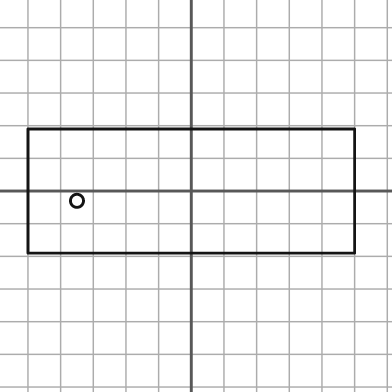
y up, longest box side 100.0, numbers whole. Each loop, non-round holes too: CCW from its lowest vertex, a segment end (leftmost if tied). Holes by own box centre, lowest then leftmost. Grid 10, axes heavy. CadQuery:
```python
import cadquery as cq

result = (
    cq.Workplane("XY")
    .moveTo(-50.0, -19.0)
    .lineTo(50.0, -19.0)
    .lineTo(50.0, 19.0)
    .lineTo(-50.0, 19.0)
    .close()
    .moveTo(-35.0, -3.0)
    .circle(2.0)
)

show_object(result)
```